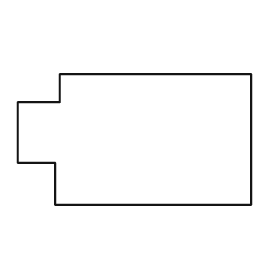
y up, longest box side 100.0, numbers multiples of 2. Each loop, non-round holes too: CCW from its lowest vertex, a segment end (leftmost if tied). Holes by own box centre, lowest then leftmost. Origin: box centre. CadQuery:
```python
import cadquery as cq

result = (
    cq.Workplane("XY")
    .moveTo(-34.0, -28.0)
    .lineTo(50.0, -28.0)
    .lineTo(50.0, 28.0)
    .lineTo(-32.0, 28.0)
    .lineTo(-32.0, 16.0)
    .lineTo(-50.0, 16.0)
    .lineTo(-50.0, -10.0)
    .lineTo(-34.0, -10.0)
    .close()
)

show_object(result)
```